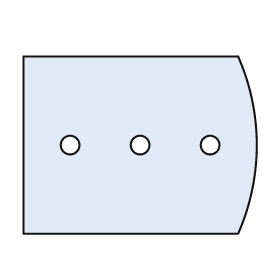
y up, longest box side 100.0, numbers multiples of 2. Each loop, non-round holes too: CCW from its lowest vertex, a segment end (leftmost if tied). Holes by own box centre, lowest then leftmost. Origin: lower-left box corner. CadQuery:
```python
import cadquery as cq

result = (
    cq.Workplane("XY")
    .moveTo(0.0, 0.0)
    .lineTo(92.0, 0.0)
    .threePointArc((100.0, 38.0), (92.0, 76.0))
    .lineTo(0.0, 76.0)
    .close()
    .moveTo(20.0, 38.0)
    .circle(4.0)
    .moveTo(50.0, 38.0)
    .circle(4.0)
    .moveTo(80.0, 38.0)
    .circle(4.0)
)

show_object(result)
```